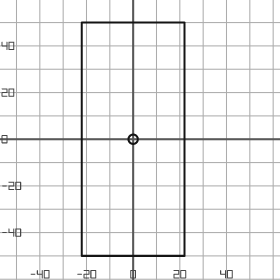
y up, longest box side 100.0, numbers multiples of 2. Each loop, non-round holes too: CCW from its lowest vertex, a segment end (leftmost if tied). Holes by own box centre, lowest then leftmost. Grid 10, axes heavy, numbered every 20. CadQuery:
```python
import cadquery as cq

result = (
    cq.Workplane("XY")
    .moveTo(-22.0, -50.0)
    .lineTo(22.0, -50.0)
    .lineTo(22.0, 50.0)
    .lineTo(-22.0, 50.0)
    .close()
    .moveTo(0.0, 0.0)
    .circle(2.0)
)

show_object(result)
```